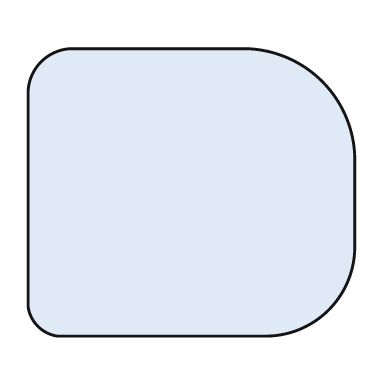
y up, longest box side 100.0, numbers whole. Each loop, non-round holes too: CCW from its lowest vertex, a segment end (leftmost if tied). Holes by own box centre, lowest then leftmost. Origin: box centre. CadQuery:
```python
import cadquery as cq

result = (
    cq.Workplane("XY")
    .moveTo(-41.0, -44.0)
    .lineTo(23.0, -44.0)
    .threePointArc((42.0, -36.0), (50.0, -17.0))
    .lineTo(50.0, 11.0)
    .threePointArc((40.0, 34.0), (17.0, 44.0))
    .lineTo(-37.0, 44.0)
    .threePointArc((-46.0, 40.0), (-50.0, 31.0))
    .lineTo(-50.0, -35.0)
    .threePointArc((-47.0, -41.0), (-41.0, -44.0))
    .close()
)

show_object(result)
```